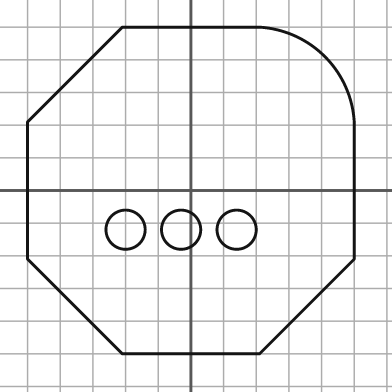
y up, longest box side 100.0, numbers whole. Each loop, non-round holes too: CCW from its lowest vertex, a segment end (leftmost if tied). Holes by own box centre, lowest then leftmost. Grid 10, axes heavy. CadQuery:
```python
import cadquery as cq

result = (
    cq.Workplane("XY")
    .moveTo(-21.0, -50.0)
    .lineTo(21.0, -50.0)
    .lineTo(50.0, -21.0)
    .lineTo(50.0, 21.0)
    .threePointArc((41.0, 41.0), (21.0, 50.0))
    .lineTo(-21.0, 50.0)
    .lineTo(-50.0, 21.0)
    .lineTo(-50.0, -21.0)
    .close()
    .moveTo(-20.0, -12.0)
    .circle(6.0)
    .moveTo(-3.0, -12.0)
    .circle(6.0)
    .moveTo(14.0, -12.0)
    .circle(6.0)
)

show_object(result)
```